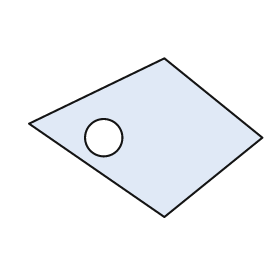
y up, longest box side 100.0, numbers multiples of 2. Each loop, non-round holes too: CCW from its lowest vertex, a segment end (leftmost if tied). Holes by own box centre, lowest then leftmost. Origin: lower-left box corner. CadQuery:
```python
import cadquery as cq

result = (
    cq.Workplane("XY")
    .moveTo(58.0, 0.0)
    .lineTo(100.0, 34.0)
    .lineTo(58.0, 68.0)
    .lineTo(0.0, 40.0)
    .close()
    .moveTo(32.0, 34.0)
    .circle(8.0)
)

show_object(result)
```